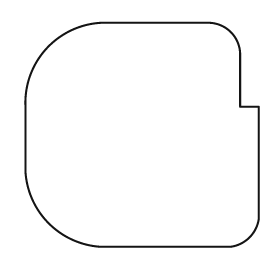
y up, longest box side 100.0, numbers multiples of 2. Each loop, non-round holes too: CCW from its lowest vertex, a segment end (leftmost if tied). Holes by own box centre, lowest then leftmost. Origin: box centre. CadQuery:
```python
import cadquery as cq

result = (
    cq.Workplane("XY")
    .moveTo(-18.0, -48.0)
    .lineTo(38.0, -48.0)
    .threePointArc((46.0, -44.0), (50.0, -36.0))
    .lineTo(50.0, 12.0)
    .lineTo(42.0, 12.0)
    .lineTo(42.0, 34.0)
    .threePointArc((38.0, 44.0), (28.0, 48.0))
    .lineTo(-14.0, 48.0)
    .threePointArc((-40.0, 38.0), (-50.0, 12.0))
    .lineTo(-50.0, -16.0)
    .threePointArc((-40.0, -38.0), (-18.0, -48.0))
    .close()
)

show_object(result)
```